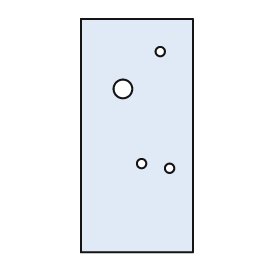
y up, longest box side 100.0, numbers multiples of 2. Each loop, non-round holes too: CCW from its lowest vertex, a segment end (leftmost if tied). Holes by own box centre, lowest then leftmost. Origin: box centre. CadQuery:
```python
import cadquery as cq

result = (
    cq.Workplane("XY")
    .moveTo(-24.0, -50.0)
    .lineTo(24.0, -50.0)
    .lineTo(24.0, 50.0)
    .lineTo(-24.0, 50.0)
    .close()
    .moveTo(14.0, -14.0)
    .circle(2.0)
    .moveTo(2.0, -12.0)
    .circle(2.0)
    .moveTo(-6.0, 20.0)
    .circle(4.0)
    .moveTo(10.0, 36.0)
    .circle(2.0)
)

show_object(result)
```